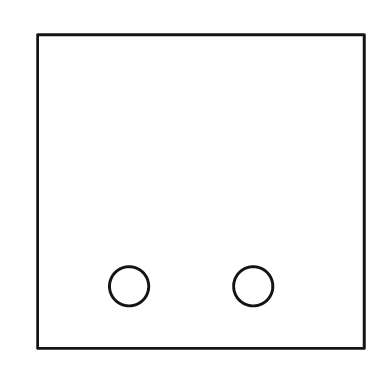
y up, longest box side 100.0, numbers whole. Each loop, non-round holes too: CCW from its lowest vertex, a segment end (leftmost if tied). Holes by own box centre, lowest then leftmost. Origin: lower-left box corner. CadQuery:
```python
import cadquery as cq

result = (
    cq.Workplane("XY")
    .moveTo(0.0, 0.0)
    .lineTo(100.0, 0.0)
    .lineTo(100.0, 96.0)
    .lineTo(0.0, 96.0)
    .close()
    .moveTo(28.0, 19.0)
    .circle(6.0)
    .moveTo(66.0, 19.0)
    .circle(6.0)
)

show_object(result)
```